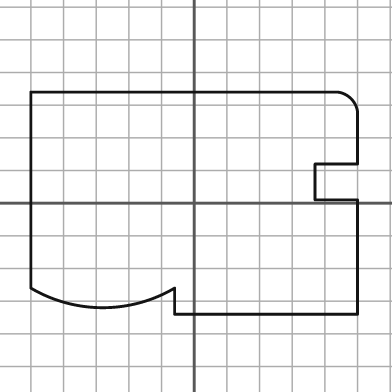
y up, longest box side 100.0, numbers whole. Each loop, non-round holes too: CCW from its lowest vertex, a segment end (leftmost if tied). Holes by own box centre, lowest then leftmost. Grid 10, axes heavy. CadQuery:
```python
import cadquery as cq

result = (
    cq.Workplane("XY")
    .moveTo(-6.0, -34.0)
    .lineTo(50.0, -34.0)
    .lineTo(50.0, 1.0)
    .lineTo(37.0, 1.0)
    .lineTo(37.0, 12.0)
    .lineTo(50.0, 12.0)
    .lineTo(50.0, 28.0)
    .threePointArc((48.0, 32.0), (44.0, 34.0))
    .lineTo(-50.0, 34.0)
    .lineTo(-50.0, -26.0)
    .threePointArc((-28.0, -32.0), (-6.0, -26.0))
    .close()
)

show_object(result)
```